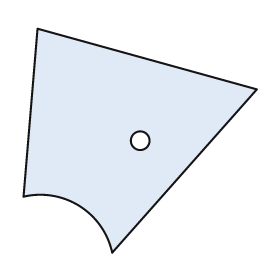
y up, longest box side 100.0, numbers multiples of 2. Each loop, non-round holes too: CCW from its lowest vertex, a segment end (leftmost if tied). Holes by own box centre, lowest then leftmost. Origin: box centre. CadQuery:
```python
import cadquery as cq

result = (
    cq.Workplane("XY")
    .moveTo(-12.0, -48.0)
    .lineTo(50.0, 22.0)
    .lineTo(-44.0, 48.0)
    .lineTo(-50.0, -24.0)
    .threePointArc((-26.0, -28.0), (-12.0, -48.0))
    .close()
    .moveTo(0.0, 0.0)
    .circle(4.0)
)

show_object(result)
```